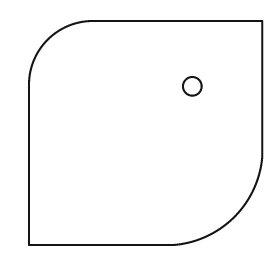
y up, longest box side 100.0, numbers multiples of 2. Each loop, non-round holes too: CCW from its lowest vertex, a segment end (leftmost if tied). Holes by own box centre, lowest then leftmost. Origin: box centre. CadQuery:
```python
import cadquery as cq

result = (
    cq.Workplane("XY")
    .moveTo(-50.0, -48.0)
    .lineTo(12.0, -48.0)
    .threePointArc((38.0, -36.0), (50.0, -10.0))
    .lineTo(50.0, 48.0)
    .lineTo(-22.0, 48.0)
    .threePointArc((-42.0, 40.0), (-50.0, 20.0))
    .close()
    .moveTo(20.0, 20.0)
    .circle(4.0)
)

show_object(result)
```